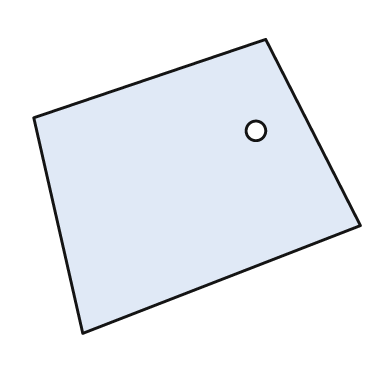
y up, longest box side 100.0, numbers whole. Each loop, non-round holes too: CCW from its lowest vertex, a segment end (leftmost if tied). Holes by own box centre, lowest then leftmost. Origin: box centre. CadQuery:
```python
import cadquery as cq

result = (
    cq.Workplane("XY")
    .moveTo(-35.0, -45.0)
    .lineTo(50.0, -12.0)
    .lineTo(21.0, 45.0)
    .lineTo(-50.0, 21.0)
    .close()
    .moveTo(18.0, 17.0)
    .circle(3.0)
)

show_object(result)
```